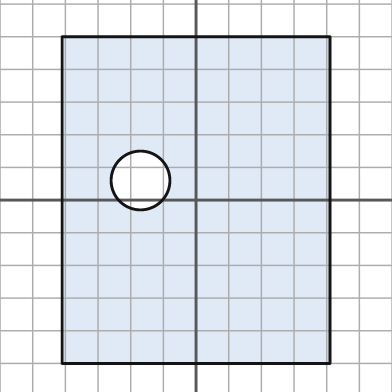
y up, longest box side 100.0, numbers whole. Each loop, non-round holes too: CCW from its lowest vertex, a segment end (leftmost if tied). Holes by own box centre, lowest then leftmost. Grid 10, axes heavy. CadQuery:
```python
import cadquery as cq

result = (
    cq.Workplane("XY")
    .moveTo(-41.0, -50.0)
    .lineTo(41.0, -50.0)
    .lineTo(41.0, 50.0)
    .lineTo(-41.0, 50.0)
    .close()
    .moveTo(-17.0, 6.0)
    .circle(9.0)
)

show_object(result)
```